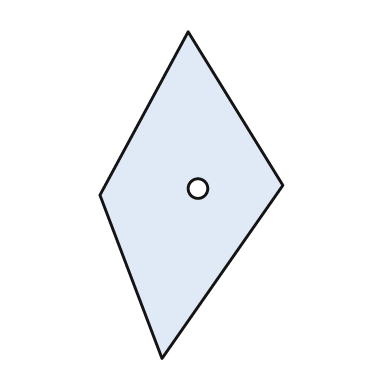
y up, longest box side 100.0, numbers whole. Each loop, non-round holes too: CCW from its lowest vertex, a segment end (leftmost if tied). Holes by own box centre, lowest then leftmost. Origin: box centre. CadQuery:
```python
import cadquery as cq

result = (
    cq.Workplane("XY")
    .moveTo(-9.0, -50.0)
    .lineTo(28.0, 3.0)
    .lineTo(-1.0, 50.0)
    .lineTo(-28.0, 0.0)
    .close()
    .moveTo(2.0, 2.0)
    .circle(3.0)
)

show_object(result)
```